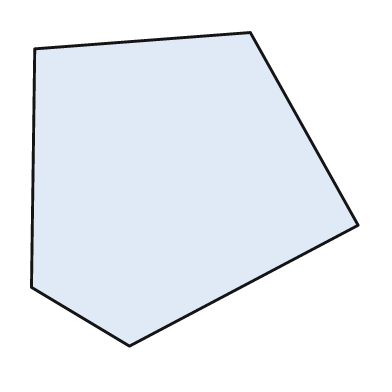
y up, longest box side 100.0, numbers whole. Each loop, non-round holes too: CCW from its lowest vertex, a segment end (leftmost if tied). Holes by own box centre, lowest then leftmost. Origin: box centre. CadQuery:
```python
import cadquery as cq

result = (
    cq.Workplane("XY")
    .moveTo(-20.0, -48.0)
    .lineTo(50.0, -11.0)
    .lineTo(17.0, 48.0)
    .lineTo(-49.0, 43.0)
    .lineTo(-50.0, -30.0)
    .close()
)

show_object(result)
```